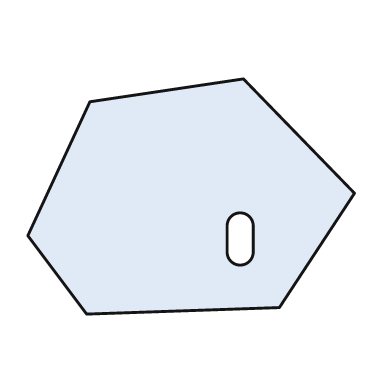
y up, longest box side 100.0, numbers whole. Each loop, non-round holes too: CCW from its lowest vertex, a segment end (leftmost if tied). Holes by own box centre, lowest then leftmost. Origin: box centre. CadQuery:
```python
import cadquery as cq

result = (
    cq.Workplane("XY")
    .moveTo(-32.0, -36.0)
    .lineTo(27.0, -34.0)
    .lineTo(50.0, 1.0)
    .lineTo(16.0, 36.0)
    .lineTo(-31.0, 29.0)
    .lineTo(-50.0, -12.0)
    .close()
    .moveTo(11.0, -17.0)
    .threePointArc((15.0, -21.0), (19.0, -17.0))
    .lineTo(19.0, -9.0)
    .threePointArc((15.0, -5.0), (11.0, -9.0))
    .close()
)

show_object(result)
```